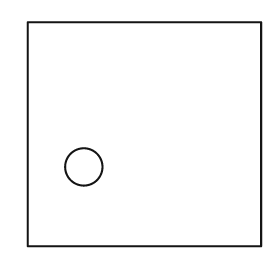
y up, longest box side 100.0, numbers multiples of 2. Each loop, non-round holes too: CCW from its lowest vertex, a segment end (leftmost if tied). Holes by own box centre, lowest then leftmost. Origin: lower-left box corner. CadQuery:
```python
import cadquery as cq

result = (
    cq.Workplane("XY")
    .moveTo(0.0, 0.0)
    .lineTo(100.0, 0.0)
    .lineTo(100.0, 96.0)
    .lineTo(0.0, 96.0)
    .close()
    .moveTo(24.0, 34.0)
    .circle(8.0)
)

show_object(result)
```